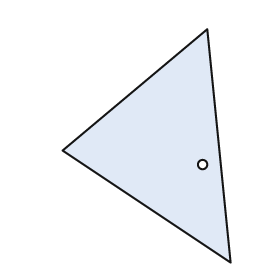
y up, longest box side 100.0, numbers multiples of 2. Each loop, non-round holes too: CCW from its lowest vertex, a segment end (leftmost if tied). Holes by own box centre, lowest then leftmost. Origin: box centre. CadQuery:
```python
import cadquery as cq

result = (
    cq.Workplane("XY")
    .moveTo(36.0, -50.0)
    .lineTo(26.0, 50.0)
    .lineTo(-36.0, -2.0)
    .close()
    .moveTo(24.0, -8.0)
    .circle(2.0)
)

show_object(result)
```